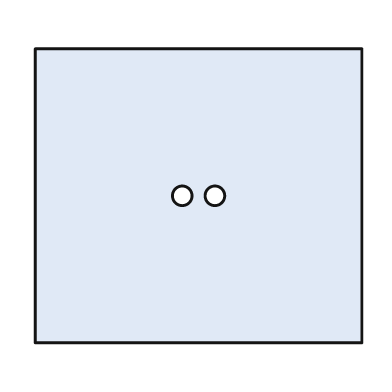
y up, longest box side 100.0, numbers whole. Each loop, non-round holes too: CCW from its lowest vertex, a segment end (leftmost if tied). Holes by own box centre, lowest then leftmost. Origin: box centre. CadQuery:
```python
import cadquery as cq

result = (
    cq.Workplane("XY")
    .moveTo(-50.0, -45.0)
    .lineTo(50.0, -45.0)
    .lineTo(50.0, 45.0)
    .lineTo(-50.0, 45.0)
    .close()
    .moveTo(-5.0, 0.0)
    .circle(3.0)
    .moveTo(5.0, 0.0)
    .circle(3.0)
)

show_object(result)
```